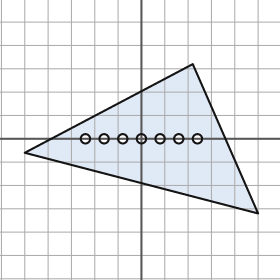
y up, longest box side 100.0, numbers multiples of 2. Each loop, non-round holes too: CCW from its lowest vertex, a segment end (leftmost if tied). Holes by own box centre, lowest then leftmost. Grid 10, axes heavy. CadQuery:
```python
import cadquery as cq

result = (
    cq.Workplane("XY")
    .moveTo(50.0, -32.0)
    .lineTo(22.0, 32.0)
    .lineTo(-50.0, -6.0)
    .close()
    .moveTo(-24.0, 0.0)
    .circle(2.0)
    .moveTo(-16.0, 0.0)
    .circle(2.0)
    .moveTo(-8.0, 0.0)
    .circle(2.0)
    .moveTo(0.0, 0.0)
    .circle(2.0)
    .moveTo(8.0, 0.0)
    .circle(2.0)
    .moveTo(16.0, 0.0)
    .circle(2.0)
    .moveTo(24.0, 0.0)
    .circle(2.0)
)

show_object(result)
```